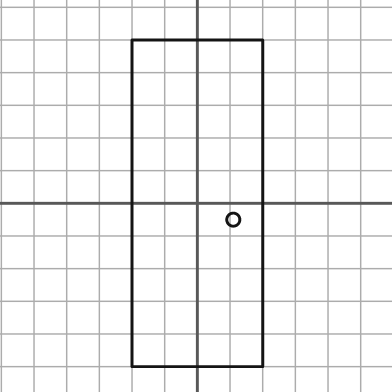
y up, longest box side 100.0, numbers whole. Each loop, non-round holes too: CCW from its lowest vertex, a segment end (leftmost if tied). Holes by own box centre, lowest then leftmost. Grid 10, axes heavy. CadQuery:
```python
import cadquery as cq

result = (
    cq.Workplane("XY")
    .moveTo(-20.0, -50.0)
    .lineTo(20.0, -50.0)
    .lineTo(20.0, 50.0)
    .lineTo(-20.0, 50.0)
    .close()
    .moveTo(11.0, -5.0)
    .circle(2.0)
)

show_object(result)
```